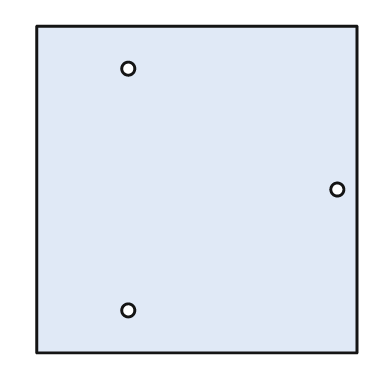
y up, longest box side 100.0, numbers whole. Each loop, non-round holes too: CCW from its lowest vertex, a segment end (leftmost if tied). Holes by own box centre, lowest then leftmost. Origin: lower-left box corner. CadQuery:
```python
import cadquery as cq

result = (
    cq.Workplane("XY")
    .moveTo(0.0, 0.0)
    .lineTo(98.0, 0.0)
    .lineTo(98.0, 100.0)
    .lineTo(0.0, 100.0)
    .close()
    .moveTo(28.0, 13.0)
    .circle(2.0)
    .moveTo(92.0, 50.0)
    .circle(2.0)
    .moveTo(28.0, 87.0)
    .circle(2.0)
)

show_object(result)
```